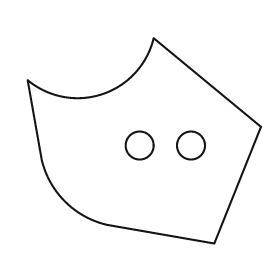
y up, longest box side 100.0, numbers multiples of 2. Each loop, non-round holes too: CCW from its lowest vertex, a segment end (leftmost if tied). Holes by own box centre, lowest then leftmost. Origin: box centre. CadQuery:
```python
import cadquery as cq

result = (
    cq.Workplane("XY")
    .moveTo(30.0, -44.0)
    .lineTo(50.0, 6.0)
    .lineTo(4.0, 44.0)
    .threePointArc((-18.0, 20.0), (-50.0, 26.0))
    .lineTo(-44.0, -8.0)
    .threePointArc((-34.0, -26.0), (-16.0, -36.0))
    .close()
    .moveTo(-2.0, -2.0)
    .circle(6.0)
    .moveTo(20.0, -2.0)
    .circle(6.0)
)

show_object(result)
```